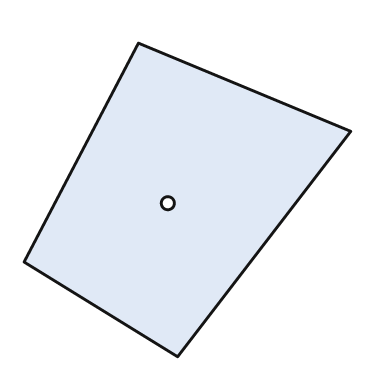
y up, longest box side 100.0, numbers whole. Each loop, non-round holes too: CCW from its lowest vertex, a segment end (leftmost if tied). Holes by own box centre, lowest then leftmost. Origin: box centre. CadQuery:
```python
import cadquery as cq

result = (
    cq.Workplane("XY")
    .moveTo(-3.0, -48.0)
    .lineTo(50.0, 21.0)
    .lineTo(-15.0, 48.0)
    .lineTo(-50.0, -19.0)
    .close()
    .moveTo(-6.0, -1.0)
    .circle(2.0)
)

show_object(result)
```